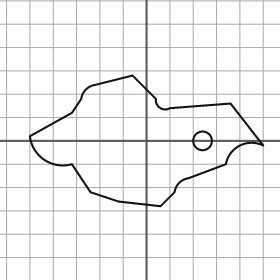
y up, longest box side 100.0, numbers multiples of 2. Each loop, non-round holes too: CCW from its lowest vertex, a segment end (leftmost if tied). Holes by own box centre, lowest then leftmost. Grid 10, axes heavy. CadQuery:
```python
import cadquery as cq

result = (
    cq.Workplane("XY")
    .moveTo(6.0, -28.0)
    .lineTo(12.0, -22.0)
    .threePointArc((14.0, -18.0), (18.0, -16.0))
    .lineTo(34.0, -10.0)
    .threePointArc((40.0, -2.0), (50.0, -2.0))
    .lineTo(36.0, 16.0)
    .lineTo(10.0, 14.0)
    .threePointArc((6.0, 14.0), (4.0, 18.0))
    .lineTo(-6.0, 28.0)
    .lineTo(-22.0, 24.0)
    .threePointArc((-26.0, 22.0), (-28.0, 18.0))
    .lineTo(-32.0, 12.0)
    .lineTo(-50.0, 2.0)
    .threePointArc((-44.0, -8.0), (-32.0, -10.0))
    .lineTo(-24.0, -22.0)
    .lineTo(-12.0, -26.0)
    .close()
    .moveTo(24.0, 0.0)
    .circle(4.0)
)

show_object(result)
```